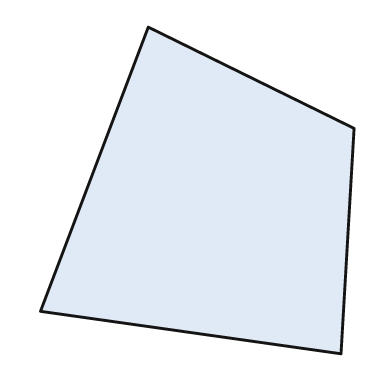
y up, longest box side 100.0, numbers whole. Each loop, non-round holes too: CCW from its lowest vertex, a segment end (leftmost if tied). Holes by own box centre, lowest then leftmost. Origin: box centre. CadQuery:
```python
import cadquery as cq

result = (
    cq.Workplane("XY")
    .moveTo(44.0, -50.0)
    .lineTo(48.0, 19.0)
    .lineTo(-15.0, 50.0)
    .lineTo(-48.0, -37.0)
    .close()
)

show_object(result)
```